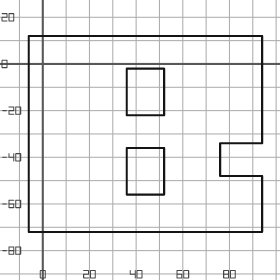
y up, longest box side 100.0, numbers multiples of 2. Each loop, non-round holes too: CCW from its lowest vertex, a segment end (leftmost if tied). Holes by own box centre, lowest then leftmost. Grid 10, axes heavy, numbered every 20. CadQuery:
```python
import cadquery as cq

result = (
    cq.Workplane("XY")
    .moveTo(-6.0, -72.0)
    .lineTo(94.0, -72.0)
    .lineTo(94.0, -48.0)
    .lineTo(76.0, -48.0)
    .lineTo(76.0, -34.0)
    .lineTo(94.0, -34.0)
    .lineTo(94.0, 12.0)
    .lineTo(-6.0, 12.0)
    .close()
    .moveTo(36.0, -56.0)
    .lineTo(52.0, -56.0)
    .lineTo(52.0, -36.0)
    .lineTo(36.0, -36.0)
    .close()
    .moveTo(36.0, -22.0)
    .lineTo(52.0, -22.0)
    .lineTo(52.0, -2.0)
    .lineTo(36.0, -2.0)
    .close()
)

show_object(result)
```